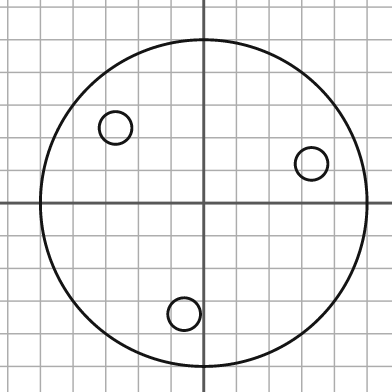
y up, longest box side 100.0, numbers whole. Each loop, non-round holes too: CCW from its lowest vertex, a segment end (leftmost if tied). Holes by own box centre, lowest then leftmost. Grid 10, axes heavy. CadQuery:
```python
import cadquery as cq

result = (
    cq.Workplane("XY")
    .moveTo(0.0, 0.0)
    .circle(50.0)
    .moveTo(-6.0, -34.0)
    .circle(5.0)
    .moveTo(33.0, 12.0)
    .circle(5.0)
    .moveTo(-27.0, 23.0)
    .circle(5.0)
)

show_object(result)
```